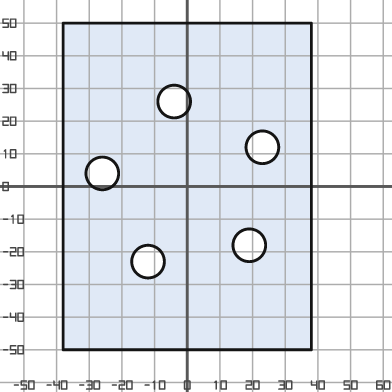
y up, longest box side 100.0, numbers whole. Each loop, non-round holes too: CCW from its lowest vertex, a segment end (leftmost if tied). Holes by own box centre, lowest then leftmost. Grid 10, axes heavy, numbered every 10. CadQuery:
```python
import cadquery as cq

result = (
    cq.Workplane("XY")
    .moveTo(-38.0, -50.0)
    .lineTo(38.0, -50.0)
    .lineTo(38.0, 50.0)
    .lineTo(-38.0, 50.0)
    .close()
    .moveTo(-12.0, -23.0)
    .circle(5.0)
    .moveTo(19.0, -18.0)
    .circle(5.0)
    .moveTo(-26.0, 4.0)
    .circle(5.0)
    .moveTo(23.0, 12.0)
    .circle(5.0)
    .moveTo(-4.0, 26.0)
    .circle(5.0)
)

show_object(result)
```